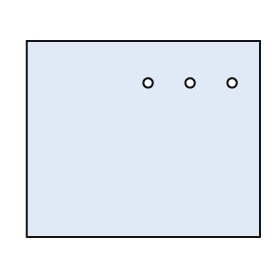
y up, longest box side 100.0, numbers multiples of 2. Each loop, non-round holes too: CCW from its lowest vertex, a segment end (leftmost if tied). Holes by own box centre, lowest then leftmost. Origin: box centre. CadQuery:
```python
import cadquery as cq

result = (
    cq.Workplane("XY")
    .moveTo(-50.0, -42.0)
    .lineTo(50.0, -42.0)
    .lineTo(50.0, 42.0)
    .lineTo(-50.0, 42.0)
    .close()
    .moveTo(2.0, 24.0)
    .circle(2.0)
    .moveTo(20.0, 24.0)
    .circle(2.0)
    .moveTo(38.0, 24.0)
    .circle(2.0)
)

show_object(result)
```